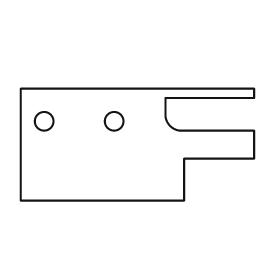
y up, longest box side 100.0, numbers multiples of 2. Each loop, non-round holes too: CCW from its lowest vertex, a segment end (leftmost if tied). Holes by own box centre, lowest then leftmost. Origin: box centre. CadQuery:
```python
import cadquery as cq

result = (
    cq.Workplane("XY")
    .moveTo(-50.0, -24.0)
    .lineTo(20.0, -24.0)
    .lineTo(20.0, -6.0)
    .lineTo(50.0, -6.0)
    .lineTo(50.0, 6.0)
    .lineTo(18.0, 6.0)
    .threePointArc((14.0, 8.0), (12.0, 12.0))
    .lineTo(12.0, 20.0)
    .lineTo(50.0, 20.0)
    .lineTo(50.0, 24.0)
    .lineTo(-50.0, 24.0)
    .close()
    .moveTo(-40.0, 10.0)
    .circle(4.0)
    .moveTo(-10.0, 10.0)
    .circle(4.0)
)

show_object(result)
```